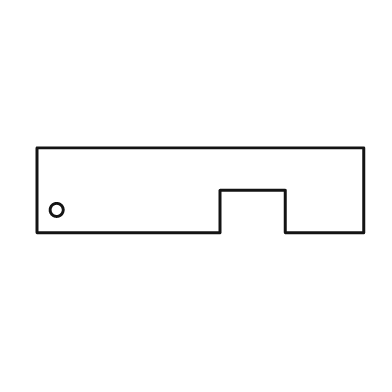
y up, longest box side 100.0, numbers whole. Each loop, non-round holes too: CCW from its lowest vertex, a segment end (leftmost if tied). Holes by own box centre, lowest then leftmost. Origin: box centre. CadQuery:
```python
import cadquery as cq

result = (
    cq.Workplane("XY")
    .moveTo(-50.0, -13.0)
    .lineTo(6.0, -13.0)
    .lineTo(6.0, 0.0)
    .lineTo(26.0, 0.0)
    .lineTo(26.0, -13.0)
    .lineTo(50.0, -13.0)
    .lineTo(50.0, 13.0)
    .lineTo(-50.0, 13.0)
    .close()
    .moveTo(-44.0, -6.0)
    .circle(2.0)
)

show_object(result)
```